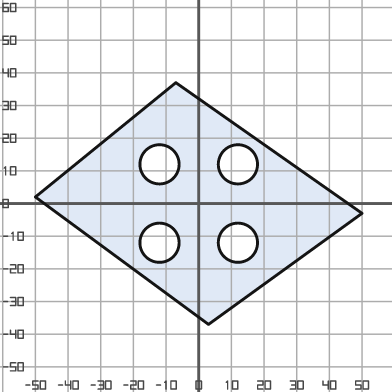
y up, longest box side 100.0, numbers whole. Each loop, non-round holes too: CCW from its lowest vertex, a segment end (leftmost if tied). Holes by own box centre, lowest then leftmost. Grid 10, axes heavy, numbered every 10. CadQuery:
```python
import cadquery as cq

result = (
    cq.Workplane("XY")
    .moveTo(3.0, -37.0)
    .lineTo(50.0, -3.0)
    .lineTo(-7.0, 37.0)
    .lineTo(-50.0, 2.0)
    .close()
    .moveTo(-12.0, -12.0)
    .circle(6.0)
    .moveTo(12.0, -12.0)
    .circle(6.0)
    .moveTo(-12.0, 12.0)
    .circle(6.0)
    .moveTo(12.0, 12.0)
    .circle(6.0)
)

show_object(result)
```